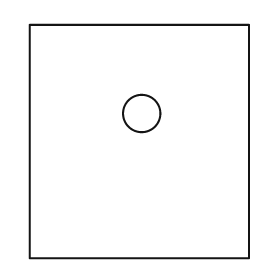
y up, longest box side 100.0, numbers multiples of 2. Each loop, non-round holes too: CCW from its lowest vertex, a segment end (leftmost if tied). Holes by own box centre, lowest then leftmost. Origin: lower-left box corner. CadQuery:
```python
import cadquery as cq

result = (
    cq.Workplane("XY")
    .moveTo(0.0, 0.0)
    .lineTo(94.0, 0.0)
    .lineTo(94.0, 100.0)
    .lineTo(0.0, 100.0)
    .close()
    .moveTo(48.0, 62.0)
    .circle(8.0)
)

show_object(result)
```